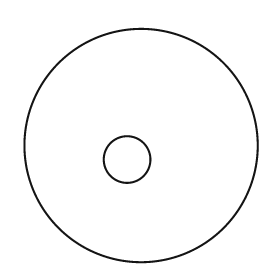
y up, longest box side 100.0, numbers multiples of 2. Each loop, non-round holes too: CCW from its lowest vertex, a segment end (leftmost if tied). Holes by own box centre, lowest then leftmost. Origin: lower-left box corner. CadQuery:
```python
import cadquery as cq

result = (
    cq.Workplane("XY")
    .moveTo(50.0, 50.0)
    .circle(50.0)
    .moveTo(44.0, 44.0)
    .circle(10.0)
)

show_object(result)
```